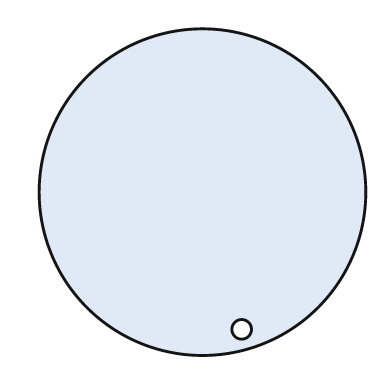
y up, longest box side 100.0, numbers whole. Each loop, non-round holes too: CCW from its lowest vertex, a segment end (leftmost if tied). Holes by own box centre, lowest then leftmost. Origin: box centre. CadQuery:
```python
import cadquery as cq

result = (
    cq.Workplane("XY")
    .moveTo(0.0, 0.0)
    .circle(50.0)
    .moveTo(12.0, -42.0)
    .circle(3.0)
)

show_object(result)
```